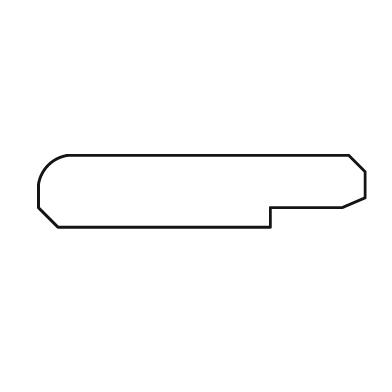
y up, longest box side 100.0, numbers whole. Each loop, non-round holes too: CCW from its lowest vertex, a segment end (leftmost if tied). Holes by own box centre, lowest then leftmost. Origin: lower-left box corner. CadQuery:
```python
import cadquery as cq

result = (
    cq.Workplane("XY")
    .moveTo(6.0, 0.0)
    .lineTo(71.0, 0.0)
    .lineTo(71.0, 6.0)
    .lineTo(93.0, 6.0)
    .lineTo(100.0, 9.0)
    .lineTo(100.0, 17.0)
    .lineTo(95.0, 22.0)
    .lineTo(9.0, 22.0)
    .threePointArc((3.0, 19.0), (0.0, 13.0))
    .lineTo(0.0, 6.0)
    .close()
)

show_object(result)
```